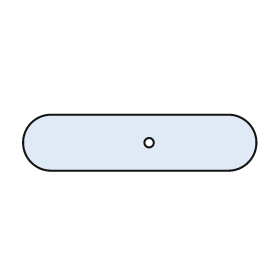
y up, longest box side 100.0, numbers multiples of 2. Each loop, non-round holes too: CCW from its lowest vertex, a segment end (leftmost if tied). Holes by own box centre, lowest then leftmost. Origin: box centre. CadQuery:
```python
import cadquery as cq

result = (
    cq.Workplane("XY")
    .moveTo(-38.0, -12.0)
    .lineTo(38.0, -12.0)
    .threePointArc((50.0, 0.0), (38.0, 12.0))
    .lineTo(-38.0, 12.0)
    .threePointArc((-50.0, 0.0), (-38.0, -12.0))
    .close()
    .moveTo(4.0, 0.0)
    .circle(2.0)
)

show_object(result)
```